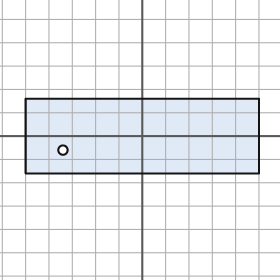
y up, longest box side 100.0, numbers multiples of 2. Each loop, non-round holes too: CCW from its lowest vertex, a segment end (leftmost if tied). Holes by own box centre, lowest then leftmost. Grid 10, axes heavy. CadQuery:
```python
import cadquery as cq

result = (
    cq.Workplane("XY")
    .moveTo(-50.0, -16.0)
    .lineTo(50.0, -16.0)
    .lineTo(50.0, 16.0)
    .lineTo(-50.0, 16.0)
    .close()
    .moveTo(-34.0, -6.0)
    .circle(2.0)
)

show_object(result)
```